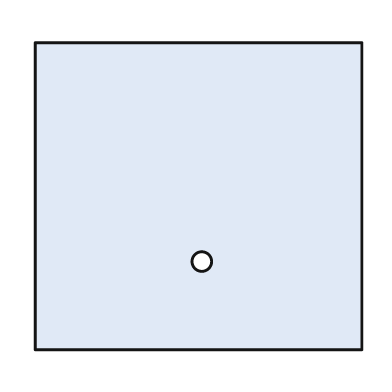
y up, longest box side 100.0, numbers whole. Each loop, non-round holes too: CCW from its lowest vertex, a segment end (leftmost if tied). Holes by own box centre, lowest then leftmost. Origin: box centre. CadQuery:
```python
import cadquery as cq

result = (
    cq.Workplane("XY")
    .moveTo(-50.0, -47.0)
    .lineTo(50.0, -47.0)
    .lineTo(50.0, 47.0)
    .lineTo(-50.0, 47.0)
    .close()
    .moveTo(1.0, -20.0)
    .circle(3.0)
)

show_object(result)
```